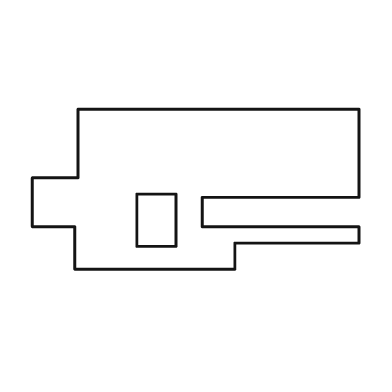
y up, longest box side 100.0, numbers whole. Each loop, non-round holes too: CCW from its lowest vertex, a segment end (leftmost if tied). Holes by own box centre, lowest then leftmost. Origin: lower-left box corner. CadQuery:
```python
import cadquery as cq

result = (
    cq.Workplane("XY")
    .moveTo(13.0, 0.0)
    .lineTo(62.0, 0.0)
    .lineTo(62.0, 8.0)
    .lineTo(100.0, 8.0)
    .lineTo(100.0, 13.0)
    .lineTo(52.0, 13.0)
    .lineTo(52.0, 22.0)
    .lineTo(100.0, 22.0)
    .lineTo(100.0, 49.0)
    .lineTo(14.0, 49.0)
    .lineTo(14.0, 28.0)
    .lineTo(0.0, 28.0)
    .lineTo(0.0, 13.0)
    .lineTo(13.0, 13.0)
    .close()
    .moveTo(32.0, 7.0)
    .lineTo(44.0, 7.0)
    .lineTo(44.0, 23.0)
    .lineTo(32.0, 23.0)
    .close()
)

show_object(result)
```